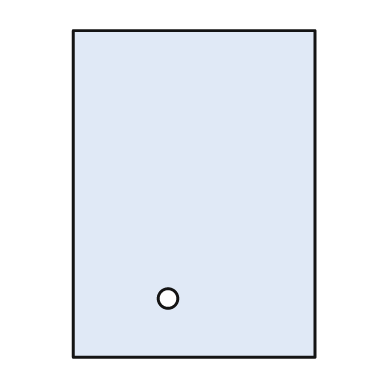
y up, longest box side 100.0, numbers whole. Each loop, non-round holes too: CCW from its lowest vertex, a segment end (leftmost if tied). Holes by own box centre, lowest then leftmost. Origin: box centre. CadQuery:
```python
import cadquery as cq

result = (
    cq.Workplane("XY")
    .moveTo(-37.0, -50.0)
    .lineTo(37.0, -50.0)
    .lineTo(37.0, 50.0)
    .lineTo(-37.0, 50.0)
    .close()
    .moveTo(-8.0, -32.0)
    .circle(3.0)
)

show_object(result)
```